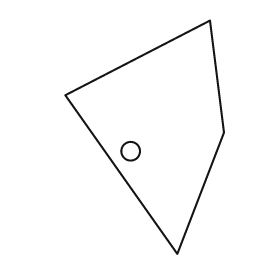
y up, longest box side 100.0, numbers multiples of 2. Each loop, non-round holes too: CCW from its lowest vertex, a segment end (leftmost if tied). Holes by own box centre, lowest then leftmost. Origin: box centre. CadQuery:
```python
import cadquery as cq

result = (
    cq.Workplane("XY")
    .moveTo(14.0, -50.0)
    .lineTo(34.0, 2.0)
    .lineTo(28.0, 50.0)
    .lineTo(-34.0, 18.0)
    .close()
    .moveTo(-6.0, -6.0)
    .circle(4.0)
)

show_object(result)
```